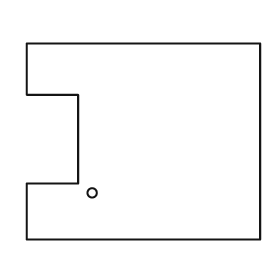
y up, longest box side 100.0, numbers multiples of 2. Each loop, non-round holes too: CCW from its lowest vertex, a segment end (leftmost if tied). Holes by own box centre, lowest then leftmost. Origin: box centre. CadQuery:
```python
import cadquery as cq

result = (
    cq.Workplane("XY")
    .moveTo(-50.0, -42.0)
    .lineTo(50.0, -42.0)
    .lineTo(50.0, 42.0)
    .lineTo(-50.0, 42.0)
    .lineTo(-50.0, 20.0)
    .lineTo(-28.0, 20.0)
    .lineTo(-28.0, -18.0)
    .lineTo(-50.0, -18.0)
    .close()
    .moveTo(-22.0, -22.0)
    .circle(2.0)
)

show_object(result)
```